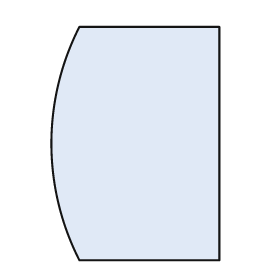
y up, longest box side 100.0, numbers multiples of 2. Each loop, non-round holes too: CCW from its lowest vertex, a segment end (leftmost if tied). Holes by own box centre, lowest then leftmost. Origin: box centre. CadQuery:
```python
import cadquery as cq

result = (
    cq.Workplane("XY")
    .moveTo(-24.0, -50.0)
    .lineTo(36.0, -50.0)
    .lineTo(36.0, 50.0)
    .lineTo(-24.0, 50.0)
    .threePointArc((-36.0, 0.0), (-24.0, -50.0))
    .close()
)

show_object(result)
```